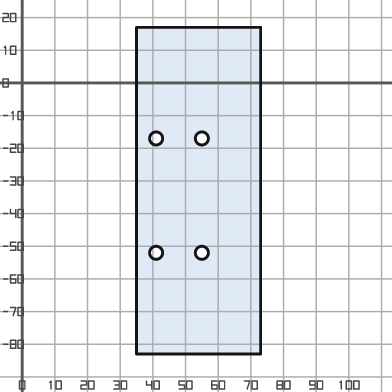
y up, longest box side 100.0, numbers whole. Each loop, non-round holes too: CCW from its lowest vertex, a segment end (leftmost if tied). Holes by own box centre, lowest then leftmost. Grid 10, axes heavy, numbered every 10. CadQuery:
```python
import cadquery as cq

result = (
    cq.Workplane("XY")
    .moveTo(35.0, -83.0)
    .lineTo(73.0, -83.0)
    .lineTo(73.0, 17.0)
    .lineTo(35.0, 17.0)
    .close()
    .moveTo(41.0, -52.0)
    .circle(2.0)
    .moveTo(55.0, -52.0)
    .circle(2.0)
    .moveTo(41.0, -17.0)
    .circle(2.0)
    .moveTo(55.0, -17.0)
    .circle(2.0)
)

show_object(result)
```